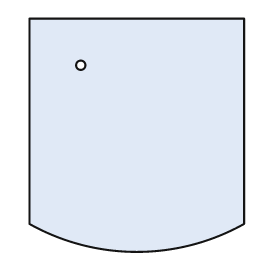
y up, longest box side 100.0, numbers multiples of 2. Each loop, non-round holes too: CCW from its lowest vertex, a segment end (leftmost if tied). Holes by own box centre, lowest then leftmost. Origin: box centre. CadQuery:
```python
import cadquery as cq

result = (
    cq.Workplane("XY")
    .moveTo(-46.0, -38.0)
    .threePointArc((0.0, -50.0), (46.0, -38.0))
    .lineTo(46.0, 50.0)
    .lineTo(-46.0, 50.0)
    .close()
    .moveTo(-24.0, 30.0)
    .circle(2.0)
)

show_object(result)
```